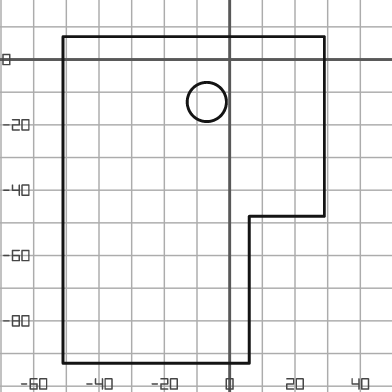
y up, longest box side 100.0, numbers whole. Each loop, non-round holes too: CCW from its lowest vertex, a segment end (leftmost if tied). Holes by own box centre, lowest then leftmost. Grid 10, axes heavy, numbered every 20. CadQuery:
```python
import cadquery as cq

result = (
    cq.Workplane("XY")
    .moveTo(-51.0, -93.0)
    .lineTo(6.0, -93.0)
    .lineTo(6.0, -48.0)
    .lineTo(29.0, -48.0)
    .lineTo(29.0, 7.0)
    .lineTo(-51.0, 7.0)
    .close()
    .moveTo(-7.0, -13.0)
    .circle(6.0)
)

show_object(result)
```